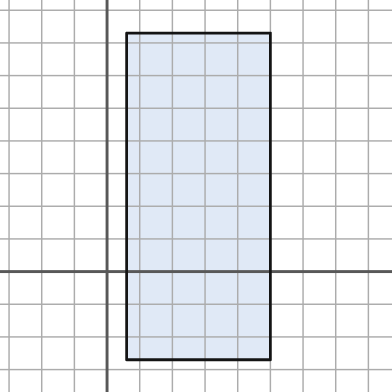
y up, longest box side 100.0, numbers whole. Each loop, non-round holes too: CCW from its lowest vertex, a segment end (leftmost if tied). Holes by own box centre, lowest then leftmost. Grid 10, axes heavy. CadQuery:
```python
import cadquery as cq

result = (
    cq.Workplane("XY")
    .moveTo(6.0, -27.0)
    .lineTo(50.0, -27.0)
    .lineTo(50.0, 73.0)
    .lineTo(6.0, 73.0)
    .close()
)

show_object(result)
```